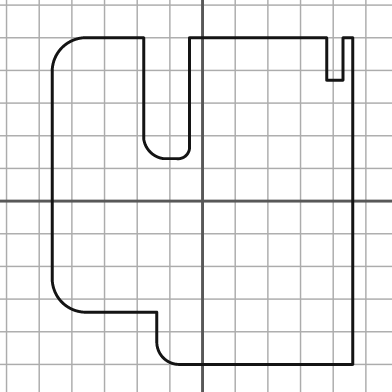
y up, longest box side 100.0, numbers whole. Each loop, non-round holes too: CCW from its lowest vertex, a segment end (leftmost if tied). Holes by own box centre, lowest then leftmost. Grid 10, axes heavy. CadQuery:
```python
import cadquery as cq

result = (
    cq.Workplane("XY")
    .moveTo(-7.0, -50.0)
    .lineTo(46.0, -50.0)
    .lineTo(46.0, 50.0)
    .lineTo(43.0, 50.0)
    .lineTo(43.0, 37.0)
    .lineTo(38.0, 37.0)
    .lineTo(38.0, 50.0)
    .lineTo(-4.0, 50.0)
    .lineTo(-4.0, 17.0)
    .threePointArc((-5.0, 14.0), (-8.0, 13.0))
    .lineTo(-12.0, 13.0)
    .threePointArc((-16.0, 15.0), (-18.0, 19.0))
    .lineTo(-18.0, 50.0)
    .lineTo(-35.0, 50.0)
    .threePointArc((-43.0, 47.0), (-46.0, 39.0))
    .lineTo(-46.0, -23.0)
    .threePointArc((-43.0, -31.0), (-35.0, -34.0))
    .lineTo(-14.0, -34.0)
    .lineTo(-14.0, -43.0)
    .threePointArc((-12.0, -48.0), (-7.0, -50.0))
    .close()
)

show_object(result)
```